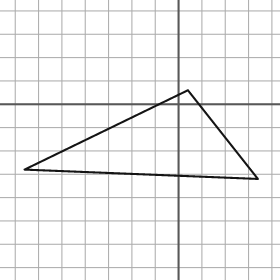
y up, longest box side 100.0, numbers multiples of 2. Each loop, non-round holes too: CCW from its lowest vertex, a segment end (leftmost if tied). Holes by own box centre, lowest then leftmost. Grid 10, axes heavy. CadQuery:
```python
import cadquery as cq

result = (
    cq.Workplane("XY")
    .moveTo(34.0, -32.0)
    .lineTo(4.0, 6.0)
    .lineTo(-66.0, -28.0)
    .close()
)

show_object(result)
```